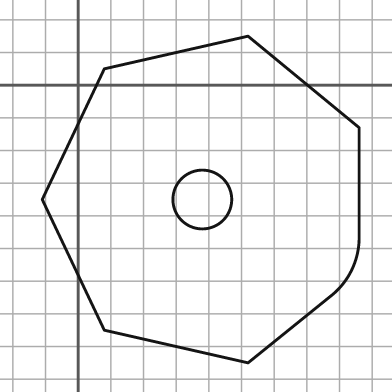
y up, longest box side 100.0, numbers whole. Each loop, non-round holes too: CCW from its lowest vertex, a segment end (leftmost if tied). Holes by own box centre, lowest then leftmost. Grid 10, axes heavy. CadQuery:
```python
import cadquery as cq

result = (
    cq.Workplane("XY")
    .moveTo(52.0, -85.0)
    .lineTo(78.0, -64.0)
    .threePointArc((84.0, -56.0), (86.0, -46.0))
    .lineTo(86.0, -13.0)
    .lineTo(52.0, 15.0)
    .lineTo(8.0, 5.0)
    .lineTo(-11.0, -35.0)
    .lineTo(8.0, -75.0)
    .close()
    .moveTo(38.0, -35.0)
    .circle(9.0)
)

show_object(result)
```